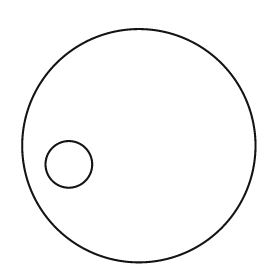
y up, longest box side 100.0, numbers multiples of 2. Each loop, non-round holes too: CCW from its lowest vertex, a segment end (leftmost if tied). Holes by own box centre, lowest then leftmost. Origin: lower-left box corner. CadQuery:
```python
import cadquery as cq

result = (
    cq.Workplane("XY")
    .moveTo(50.0, 50.0)
    .circle(50.0)
    .moveTo(20.0, 42.0)
    .circle(10.0)
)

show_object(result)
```